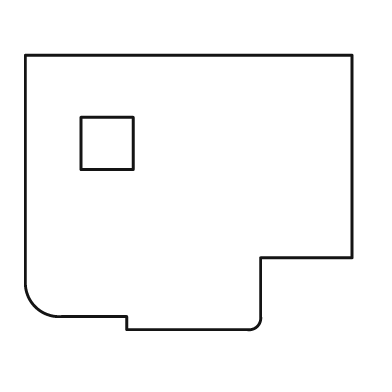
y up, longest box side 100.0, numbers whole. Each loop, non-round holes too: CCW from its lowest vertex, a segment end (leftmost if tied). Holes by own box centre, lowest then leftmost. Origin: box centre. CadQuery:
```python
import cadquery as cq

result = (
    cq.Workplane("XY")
    .moveTo(-19.0, -42.0)
    .lineTo(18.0, -42.0)
    .threePointArc((21.0, -41.0), (22.0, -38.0))
    .lineTo(22.0, -20.0)
    .lineTo(50.0, -20.0)
    .lineTo(50.0, 42.0)
    .lineTo(-50.0, 42.0)
    .lineTo(-50.0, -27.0)
    .threePointArc((-47.0, -35.0), (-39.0, -38.0))
    .lineTo(-19.0, -38.0)
    .close()
    .moveTo(-33.0, 7.0)
    .lineTo(-17.0, 7.0)
    .lineTo(-17.0, 23.0)
    .lineTo(-33.0, 23.0)
    .close()
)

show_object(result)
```